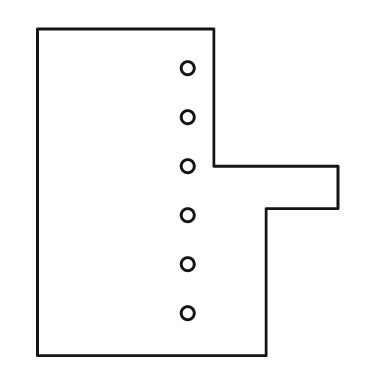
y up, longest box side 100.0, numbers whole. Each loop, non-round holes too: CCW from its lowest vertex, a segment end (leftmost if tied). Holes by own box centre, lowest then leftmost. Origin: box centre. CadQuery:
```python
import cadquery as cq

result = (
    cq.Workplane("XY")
    .moveTo(-46.0, -50.0)
    .lineTo(24.0, -50.0)
    .lineTo(24.0, -5.0)
    .lineTo(46.0, -5.0)
    .lineTo(46.0, 8.0)
    .lineTo(8.0, 8.0)
    .lineTo(8.0, 50.0)
    .lineTo(-46.0, 50.0)
    .close()
    .moveTo(0.0, -37.0)
    .circle(2.0)
    .moveTo(0.0, -22.0)
    .circle(2.0)
    .moveTo(0.0, -7.0)
    .circle(2.0)
    .moveTo(0.0, 8.0)
    .circle(2.0)
    .moveTo(0.0, 23.0)
    .circle(2.0)
    .moveTo(0.0, 38.0)
    .circle(2.0)
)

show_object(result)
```